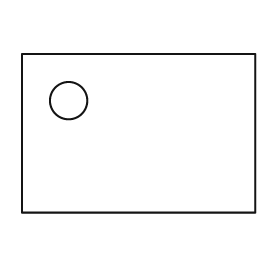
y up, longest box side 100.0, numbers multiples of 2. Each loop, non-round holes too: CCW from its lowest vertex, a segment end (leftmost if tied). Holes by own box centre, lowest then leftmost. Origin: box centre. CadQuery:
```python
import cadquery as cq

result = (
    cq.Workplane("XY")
    .moveTo(-50.0, -34.0)
    .lineTo(50.0, -34.0)
    .lineTo(50.0, 34.0)
    .lineTo(-50.0, 34.0)
    .close()
    .moveTo(-30.0, 14.0)
    .circle(8.0)
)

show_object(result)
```